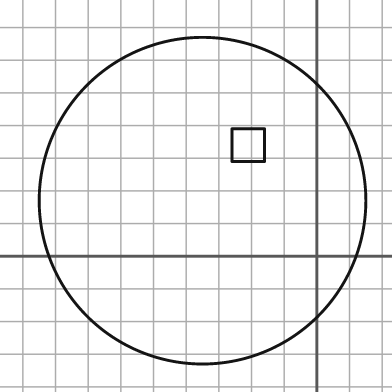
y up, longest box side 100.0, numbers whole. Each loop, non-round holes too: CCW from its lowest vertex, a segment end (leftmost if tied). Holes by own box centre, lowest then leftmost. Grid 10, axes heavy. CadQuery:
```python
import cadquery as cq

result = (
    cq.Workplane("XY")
    .moveTo(-35.0, 17.0)
    .circle(50.0)
    .moveTo(-26.0, 29.0)
    .lineTo(-16.0, 29.0)
    .lineTo(-16.0, 39.0)
    .lineTo(-26.0, 39.0)
    .close()
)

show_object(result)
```